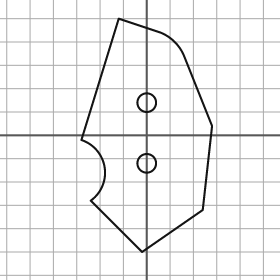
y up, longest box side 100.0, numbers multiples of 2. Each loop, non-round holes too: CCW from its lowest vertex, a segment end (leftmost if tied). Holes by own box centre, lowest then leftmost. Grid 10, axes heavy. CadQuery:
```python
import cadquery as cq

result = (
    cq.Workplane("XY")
    .moveTo(-2.0, -50.0)
    .lineTo(24.0, -32.0)
    .lineTo(28.0, 4.0)
    .lineTo(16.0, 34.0)
    .threePointArc((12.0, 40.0), (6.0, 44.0))
    .lineTo(-12.0, 50.0)
    .lineTo(-28.0, -2.0)
    .threePointArc((-18.0, -14.0), (-24.0, -28.0))
    .close()
    .moveTo(0.0, -12.0)
    .circle(4.0)
    .moveTo(0.0, 14.0)
    .circle(4.0)
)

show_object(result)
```